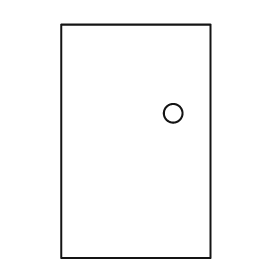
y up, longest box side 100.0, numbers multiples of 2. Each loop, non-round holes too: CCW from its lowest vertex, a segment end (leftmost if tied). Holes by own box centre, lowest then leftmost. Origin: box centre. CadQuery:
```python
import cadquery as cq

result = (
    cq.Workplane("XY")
    .moveTo(-32.0, -50.0)
    .lineTo(32.0, -50.0)
    .lineTo(32.0, 50.0)
    .lineTo(-32.0, 50.0)
    .close()
    .moveTo(16.0, 12.0)
    .circle(4.0)
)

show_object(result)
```